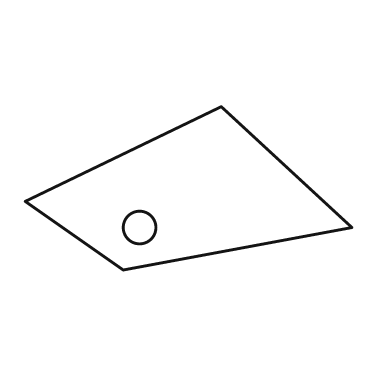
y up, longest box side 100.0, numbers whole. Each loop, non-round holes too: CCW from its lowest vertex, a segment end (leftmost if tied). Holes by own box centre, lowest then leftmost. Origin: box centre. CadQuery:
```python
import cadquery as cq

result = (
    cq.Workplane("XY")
    .moveTo(-20.0, -25.0)
    .lineTo(50.0, -12.0)
    .lineTo(10.0, 25.0)
    .lineTo(-50.0, -4.0)
    .close()
    .moveTo(-15.0, -12.0)
    .circle(5.0)
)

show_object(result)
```